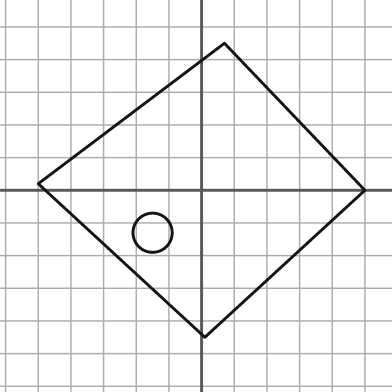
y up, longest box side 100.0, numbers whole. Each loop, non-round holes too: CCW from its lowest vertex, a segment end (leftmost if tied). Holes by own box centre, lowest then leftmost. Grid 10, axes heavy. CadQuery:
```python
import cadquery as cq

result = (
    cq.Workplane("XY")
    .moveTo(1.0, -45.0)
    .lineTo(50.0, 0.0)
    .lineTo(7.0, 45.0)
    .lineTo(-50.0, 2.0)
    .close()
    .moveTo(-15.0, -13.0)
    .circle(6.0)
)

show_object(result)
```